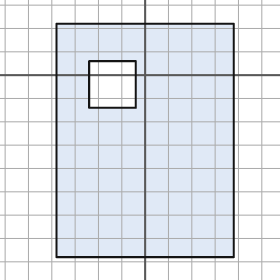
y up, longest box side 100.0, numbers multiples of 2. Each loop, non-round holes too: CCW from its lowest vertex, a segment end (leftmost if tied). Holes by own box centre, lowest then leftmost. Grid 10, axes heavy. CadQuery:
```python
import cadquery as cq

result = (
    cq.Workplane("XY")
    .moveTo(-38.0, -78.0)
    .lineTo(38.0, -78.0)
    .lineTo(38.0, 22.0)
    .lineTo(-38.0, 22.0)
    .close()
    .moveTo(-24.0, -14.0)
    .lineTo(-4.0, -14.0)
    .lineTo(-4.0, 6.0)
    .lineTo(-24.0, 6.0)
    .close()
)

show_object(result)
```